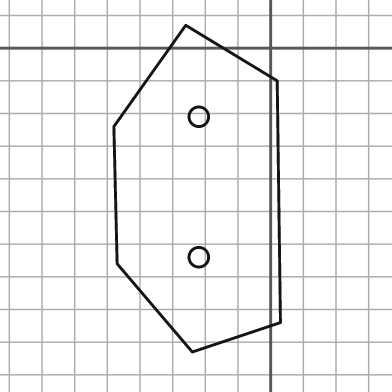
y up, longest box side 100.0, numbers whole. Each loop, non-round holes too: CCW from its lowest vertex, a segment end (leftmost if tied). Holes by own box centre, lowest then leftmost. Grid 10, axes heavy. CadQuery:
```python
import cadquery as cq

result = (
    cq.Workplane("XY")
    .moveTo(-24.0, -93.0)
    .lineTo(3.0, -84.0)
    .lineTo(2.0, -10.0)
    .lineTo(-26.0, 7.0)
    .lineTo(-48.0, -24.0)
    .lineTo(-47.0, -66.0)
    .close()
    .moveTo(-22.0, -64.0)
    .circle(3.0)
    .moveTo(-22.0, -21.0)
    .circle(3.0)
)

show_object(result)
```